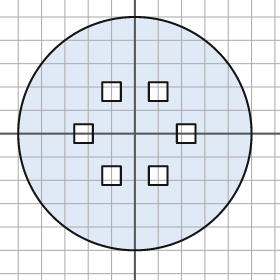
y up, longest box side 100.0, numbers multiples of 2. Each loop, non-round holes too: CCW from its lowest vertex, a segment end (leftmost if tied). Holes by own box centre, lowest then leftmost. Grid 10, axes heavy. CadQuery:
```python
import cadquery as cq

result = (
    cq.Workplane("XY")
    .moveTo(0.0, 0.0)
    .circle(50.0)
    .moveTo(-14.0, -22.0)
    .lineTo(-6.0, -22.0)
    .lineTo(-6.0, -14.0)
    .lineTo(-14.0, -14.0)
    .close()
    .moveTo(6.0, -22.0)
    .lineTo(14.0, -22.0)
    .lineTo(14.0, -14.0)
    .lineTo(6.0, -14.0)
    .close()
    .moveTo(-26.0, -4.0)
    .lineTo(-18.0, -4.0)
    .lineTo(-18.0, 4.0)
    .lineTo(-26.0, 4.0)
    .close()
    .moveTo(18.0, -4.0)
    .lineTo(26.0, -4.0)
    .lineTo(26.0, 4.0)
    .lineTo(18.0, 4.0)
    .close()
    .moveTo(-14.0, 14.0)
    .lineTo(-6.0, 14.0)
    .lineTo(-6.0, 22.0)
    .lineTo(-14.0, 22.0)
    .close()
    .moveTo(6.0, 14.0)
    .lineTo(14.0, 14.0)
    .lineTo(14.0, 22.0)
    .lineTo(6.0, 22.0)
    .close()
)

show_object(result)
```